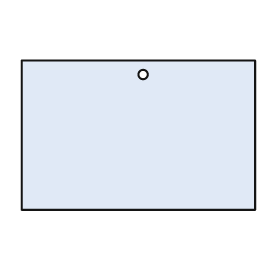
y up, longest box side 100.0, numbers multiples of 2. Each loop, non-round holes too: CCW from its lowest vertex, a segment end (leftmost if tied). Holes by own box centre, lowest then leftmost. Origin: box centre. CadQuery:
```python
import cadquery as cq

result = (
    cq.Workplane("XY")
    .moveTo(-50.0, -32.0)
    .lineTo(50.0, -32.0)
    .lineTo(50.0, 32.0)
    .lineTo(-50.0, 32.0)
    .close()
    .moveTo(2.0, 26.0)
    .circle(2.0)
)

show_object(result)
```